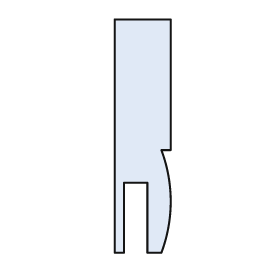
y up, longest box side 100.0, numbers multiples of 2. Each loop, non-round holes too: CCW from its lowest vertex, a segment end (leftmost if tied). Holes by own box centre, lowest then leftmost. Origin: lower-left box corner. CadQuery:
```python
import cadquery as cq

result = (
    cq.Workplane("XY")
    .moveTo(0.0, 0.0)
    .lineTo(4.0, 0.0)
    .lineTo(4.0, 30.0)
    .lineTo(14.0, 30.0)
    .lineTo(14.0, 0.0)
    .lineTo(20.0, 0.0)
    .threePointArc((24.0, 22.0), (20.0, 44.0))
    .lineTo(24.0, 44.0)
    .lineTo(24.0, 100.0)
    .lineTo(0.0, 100.0)
    .close()
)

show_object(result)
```